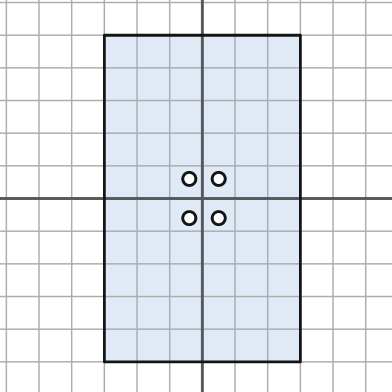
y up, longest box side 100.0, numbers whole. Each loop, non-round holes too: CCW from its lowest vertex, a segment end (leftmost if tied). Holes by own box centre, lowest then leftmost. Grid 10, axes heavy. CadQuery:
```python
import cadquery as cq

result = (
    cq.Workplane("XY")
    .moveTo(-30.0, -50.0)
    .lineTo(30.0, -50.0)
    .lineTo(30.0, 50.0)
    .lineTo(-30.0, 50.0)
    .close()
    .moveTo(-4.0, -6.0)
    .circle(2.0)
    .moveTo(5.0, -6.0)
    .circle(2.0)
    .moveTo(-4.0, 6.0)
    .circle(2.0)
    .moveTo(5.0, 6.0)
    .circle(2.0)
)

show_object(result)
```